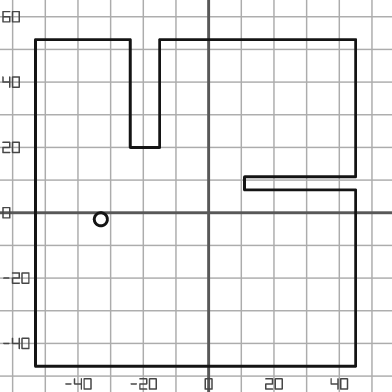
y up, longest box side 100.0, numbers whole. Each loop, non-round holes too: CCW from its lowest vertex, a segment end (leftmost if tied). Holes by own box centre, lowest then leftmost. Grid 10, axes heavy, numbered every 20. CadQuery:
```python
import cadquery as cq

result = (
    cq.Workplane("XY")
    .moveTo(-53.0, -47.0)
    .lineTo(45.0, -47.0)
    .lineTo(45.0, 7.0)
    .lineTo(11.0, 7.0)
    .lineTo(11.0, 11.0)
    .lineTo(45.0, 11.0)
    .lineTo(45.0, 53.0)
    .lineTo(-15.0, 53.0)
    .lineTo(-15.0, 20.0)
    .lineTo(-24.0, 20.0)
    .lineTo(-24.0, 53.0)
    .lineTo(-53.0, 53.0)
    .close()
    .moveTo(-33.0, -2.0)
    .circle(2.0)
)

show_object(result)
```